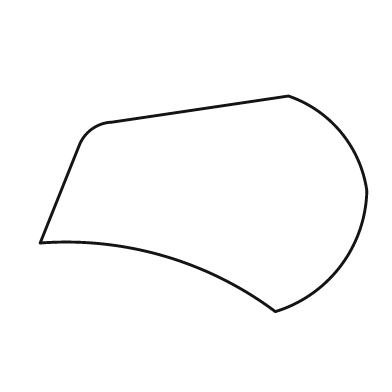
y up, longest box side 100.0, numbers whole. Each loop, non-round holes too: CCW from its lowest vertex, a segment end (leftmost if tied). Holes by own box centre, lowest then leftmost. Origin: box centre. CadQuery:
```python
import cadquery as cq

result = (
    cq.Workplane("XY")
    .moveTo(22.0, -33.0)
    .threePointArc((42.0, -19.0), (50.0, 4.0))
    .threePointArc((42.0, 22.0), (26.0, 33.0))
    .lineTo(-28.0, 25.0)
    .threePointArc((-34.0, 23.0), (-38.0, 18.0))
    .lineTo(-50.0, -12.0)
    .threePointArc((-12.0, -16.0), (22.0, -33.0))
    .close()
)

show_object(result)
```